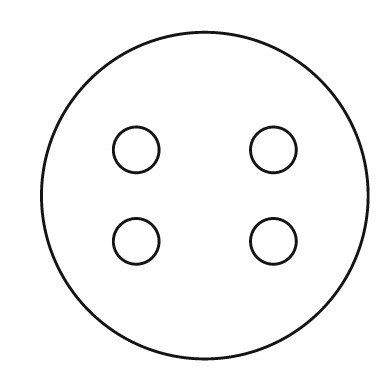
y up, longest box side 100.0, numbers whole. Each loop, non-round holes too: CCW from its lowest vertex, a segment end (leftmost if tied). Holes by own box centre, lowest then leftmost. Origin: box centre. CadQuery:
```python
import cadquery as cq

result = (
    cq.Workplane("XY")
    .moveTo(0.0, 0.0)
    .circle(50.0)
    .moveTo(-21.0, -14.0)
    .circle(7.0)
    .moveTo(21.0, -14.0)
    .circle(7.0)
    .moveTo(-21.0, 14.0)
    .circle(7.0)
    .moveTo(21.0, 14.0)
    .circle(7.0)
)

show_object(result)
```